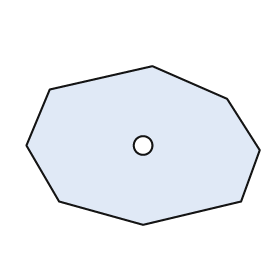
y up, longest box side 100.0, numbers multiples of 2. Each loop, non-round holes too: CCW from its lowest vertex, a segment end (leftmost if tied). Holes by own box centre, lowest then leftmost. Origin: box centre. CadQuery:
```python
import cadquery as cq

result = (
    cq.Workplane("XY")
    .moveTo(0.0, -34.0)
    .lineTo(42.0, -24.0)
    .lineTo(50.0, -2.0)
    .lineTo(36.0, 20.0)
    .lineTo(4.0, 34.0)
    .lineTo(-40.0, 24.0)
    .lineTo(-50.0, 0.0)
    .lineTo(-36.0, -24.0)
    .close()
    .moveTo(0.0, 0.0)
    .circle(4.0)
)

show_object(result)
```